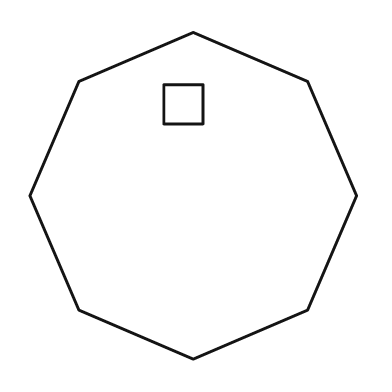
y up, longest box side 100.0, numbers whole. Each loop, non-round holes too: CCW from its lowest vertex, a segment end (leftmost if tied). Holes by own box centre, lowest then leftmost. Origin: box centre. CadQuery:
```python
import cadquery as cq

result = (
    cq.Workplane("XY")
    .moveTo(0.0, -50.0)
    .lineTo(35.0, -35.0)
    .lineTo(50.0, 0.0)
    .lineTo(35.0, 35.0)
    .lineTo(0.0, 50.0)
    .lineTo(-35.0, 35.0)
    .lineTo(-50.0, 0.0)
    .lineTo(-35.0, -35.0)
    .close()
    .moveTo(-9.0, 22.0)
    .lineTo(3.0, 22.0)
    .lineTo(3.0, 34.0)
    .lineTo(-9.0, 34.0)
    .close()
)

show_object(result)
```